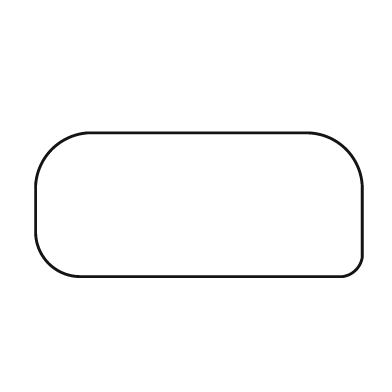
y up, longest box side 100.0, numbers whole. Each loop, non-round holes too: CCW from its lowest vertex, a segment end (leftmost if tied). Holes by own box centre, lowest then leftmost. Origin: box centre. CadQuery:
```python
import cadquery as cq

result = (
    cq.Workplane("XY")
    .moveTo(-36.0, -22.0)
    .lineTo(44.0, -22.0)
    .threePointArc((48.0, -20.0), (50.0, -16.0))
    .lineTo(50.0, 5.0)
    .threePointArc((45.0, 17.0), (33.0, 22.0))
    .lineTo(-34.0, 22.0)
    .threePointArc((-45.0, 17.0), (-50.0, 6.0))
    .lineTo(-50.0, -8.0)
    .threePointArc((-46.0, -18.0), (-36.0, -22.0))
    .close()
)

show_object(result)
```